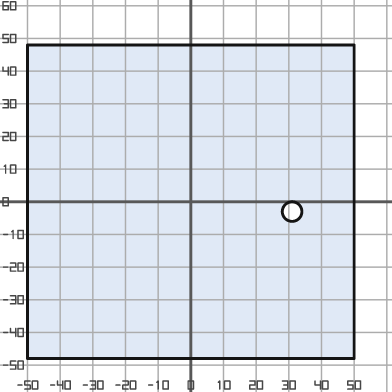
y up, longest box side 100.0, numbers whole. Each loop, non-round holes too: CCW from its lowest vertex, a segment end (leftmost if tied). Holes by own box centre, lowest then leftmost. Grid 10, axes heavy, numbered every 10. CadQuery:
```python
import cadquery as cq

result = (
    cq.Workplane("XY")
    .moveTo(-50.0, -48.0)
    .lineTo(50.0, -48.0)
    .lineTo(50.0, 48.0)
    .lineTo(-50.0, 48.0)
    .close()
    .moveTo(31.0, -3.0)
    .circle(3.0)
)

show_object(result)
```